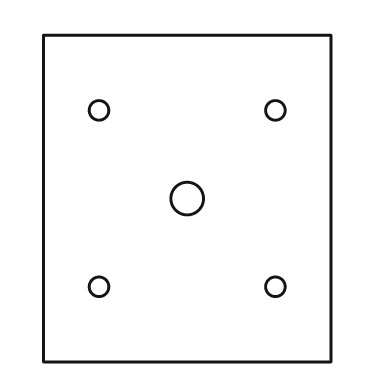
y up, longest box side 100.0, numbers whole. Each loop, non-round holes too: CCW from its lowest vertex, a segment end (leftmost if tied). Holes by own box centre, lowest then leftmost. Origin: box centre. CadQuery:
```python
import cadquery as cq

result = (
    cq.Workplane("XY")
    .moveTo(-44.0, -50.0)
    .lineTo(44.0, -50.0)
    .lineTo(44.0, 50.0)
    .lineTo(-44.0, 50.0)
    .close()
    .moveTo(-27.0, -27.0)
    .circle(3.0)
    .moveTo(27.0, -27.0)
    .circle(3.0)
    .moveTo(0.0, 0.0)
    .circle(5.0)
    .moveTo(-27.0, 27.0)
    .circle(3.0)
    .moveTo(27.0, 27.0)
    .circle(3.0)
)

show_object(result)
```